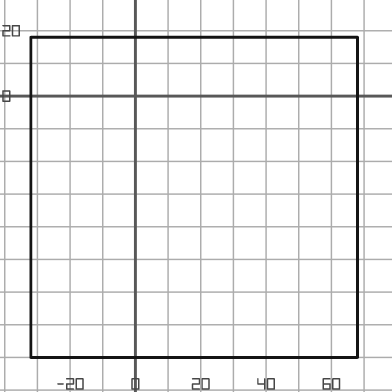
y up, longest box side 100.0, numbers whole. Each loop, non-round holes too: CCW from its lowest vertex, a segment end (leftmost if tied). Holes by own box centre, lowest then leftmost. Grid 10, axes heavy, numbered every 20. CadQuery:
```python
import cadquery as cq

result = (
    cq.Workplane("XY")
    .moveTo(-32.0, -80.0)
    .lineTo(68.0, -80.0)
    .lineTo(68.0, 18.0)
    .lineTo(-32.0, 18.0)
    .close()
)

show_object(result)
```